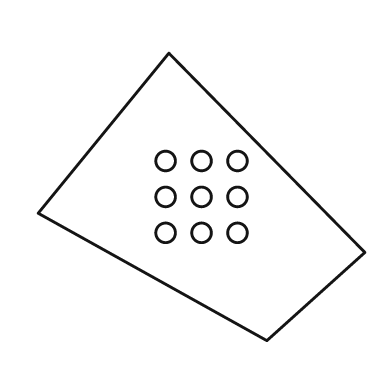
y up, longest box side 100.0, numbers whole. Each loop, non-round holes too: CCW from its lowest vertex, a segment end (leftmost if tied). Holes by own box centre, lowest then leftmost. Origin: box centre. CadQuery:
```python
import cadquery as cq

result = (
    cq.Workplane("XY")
    .moveTo(20.0, -44.0)
    .lineTo(50.0, -17.0)
    .lineTo(-10.0, 44.0)
    .lineTo(-50.0, -5.0)
    .close()
    .moveTo(-11.0, -11.0)
    .circle(3.0)
    .moveTo(0.0, -11.0)
    .circle(3.0)
    .moveTo(11.0, -11.0)
    .circle(3.0)
    .moveTo(-11.0, 0.0)
    .circle(3.0)
    .moveTo(0.0, 0.0)
    .circle(3.0)
    .moveTo(11.0, 0.0)
    .circle(3.0)
    .moveTo(-11.0, 11.0)
    .circle(3.0)
    .moveTo(0.0, 11.0)
    .circle(3.0)
    .moveTo(11.0, 11.0)
    .circle(3.0)
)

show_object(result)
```